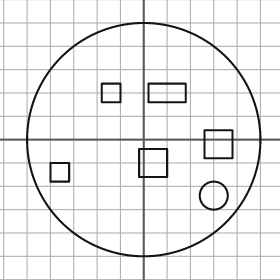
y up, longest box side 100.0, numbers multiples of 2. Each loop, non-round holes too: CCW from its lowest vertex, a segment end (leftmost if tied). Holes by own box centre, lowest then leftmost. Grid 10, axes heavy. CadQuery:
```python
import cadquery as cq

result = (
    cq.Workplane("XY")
    .moveTo(0.0, 0.0)
    .circle(50.0)
    .moveTo(30.0, -24.0)
    .circle(6.0)
    .moveTo(-40.0, -18.0)
    .lineTo(-32.0, -18.0)
    .lineTo(-32.0, -10.0)
    .lineTo(-40.0, -10.0)
    .close()
    .moveTo(-2.0, -16.0)
    .lineTo(10.0, -16.0)
    .lineTo(10.0, -4.0)
    .lineTo(-2.0, -4.0)
    .close()
    .moveTo(26.0, -8.0)
    .lineTo(38.0, -8.0)
    .lineTo(38.0, 4.0)
    .lineTo(26.0, 4.0)
    .close()
    .moveTo(-18.0, 16.0)
    .lineTo(-10.0, 16.0)
    .lineTo(-10.0, 24.0)
    .lineTo(-18.0, 24.0)
    .close()
    .moveTo(2.0, 16.0)
    .lineTo(18.0, 16.0)
    .lineTo(18.0, 24.0)
    .lineTo(2.0, 24.0)
    .close()
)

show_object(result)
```